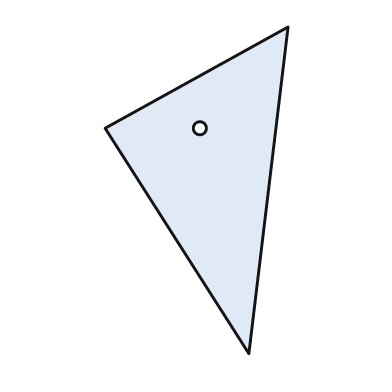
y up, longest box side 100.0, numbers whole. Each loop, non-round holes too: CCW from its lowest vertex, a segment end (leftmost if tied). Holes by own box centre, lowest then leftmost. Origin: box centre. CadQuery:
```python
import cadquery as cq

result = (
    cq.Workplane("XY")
    .moveTo(16.0, -50.0)
    .lineTo(28.0, 50.0)
    .lineTo(-28.0, 19.0)
    .close()
    .moveTo(1.0, 19.0)
    .circle(2.0)
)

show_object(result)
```